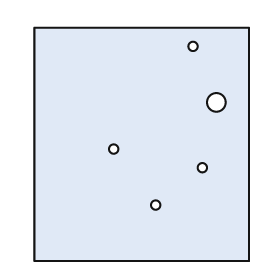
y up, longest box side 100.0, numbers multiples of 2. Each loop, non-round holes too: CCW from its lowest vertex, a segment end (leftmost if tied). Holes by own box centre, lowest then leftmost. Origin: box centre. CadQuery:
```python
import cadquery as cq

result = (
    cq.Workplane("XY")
    .moveTo(-46.0, -50.0)
    .lineTo(46.0, -50.0)
    .lineTo(46.0, 50.0)
    .lineTo(-46.0, 50.0)
    .close()
    .moveTo(6.0, -26.0)
    .circle(2.0)
    .moveTo(26.0, -10.0)
    .circle(2.0)
    .moveTo(-12.0, -2.0)
    .circle(2.0)
    .moveTo(32.0, 18.0)
    .circle(4.0)
    .moveTo(22.0, 42.0)
    .circle(2.0)
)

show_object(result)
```